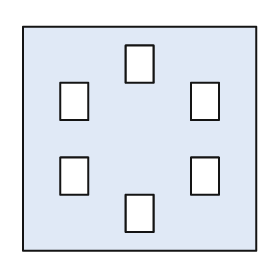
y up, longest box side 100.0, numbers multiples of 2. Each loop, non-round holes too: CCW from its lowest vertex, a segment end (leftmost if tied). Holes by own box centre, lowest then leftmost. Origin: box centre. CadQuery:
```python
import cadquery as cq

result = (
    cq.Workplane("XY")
    .moveTo(-50.0, -48.0)
    .lineTo(50.0, -48.0)
    .lineTo(50.0, 48.0)
    .lineTo(-50.0, 48.0)
    .close()
    .moveTo(-6.0, -40.0)
    .lineTo(6.0, -40.0)
    .lineTo(6.0, -24.0)
    .lineTo(-6.0, -24.0)
    .close()
    .moveTo(-34.0, -24.0)
    .lineTo(-22.0, -24.0)
    .lineTo(-22.0, -8.0)
    .lineTo(-34.0, -8.0)
    .close()
    .moveTo(22.0, -24.0)
    .lineTo(34.0, -24.0)
    .lineTo(34.0, -8.0)
    .lineTo(22.0, -8.0)
    .close()
    .moveTo(-34.0, 8.0)
    .lineTo(-22.0, 8.0)
    .lineTo(-22.0, 24.0)
    .lineTo(-34.0, 24.0)
    .close()
    .moveTo(22.0, 8.0)
    .lineTo(34.0, 8.0)
    .lineTo(34.0, 24.0)
    .lineTo(22.0, 24.0)
    .close()
    .moveTo(-6.0, 24.0)
    .lineTo(6.0, 24.0)
    .lineTo(6.0, 40.0)
    .lineTo(-6.0, 40.0)
    .close()
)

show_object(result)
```